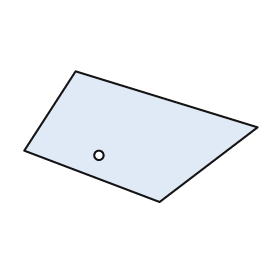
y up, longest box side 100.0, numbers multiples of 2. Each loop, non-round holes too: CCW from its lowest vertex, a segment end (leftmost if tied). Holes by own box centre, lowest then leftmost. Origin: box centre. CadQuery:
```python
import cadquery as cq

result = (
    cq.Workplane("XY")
    .moveTo(8.0, -28.0)
    .lineTo(50.0, 4.0)
    .lineTo(-28.0, 28.0)
    .lineTo(-50.0, -6.0)
    .close()
    .moveTo(-18.0, -8.0)
    .circle(2.0)
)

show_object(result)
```